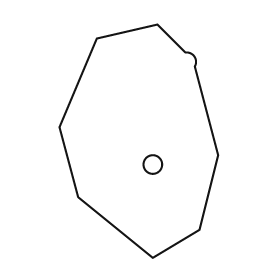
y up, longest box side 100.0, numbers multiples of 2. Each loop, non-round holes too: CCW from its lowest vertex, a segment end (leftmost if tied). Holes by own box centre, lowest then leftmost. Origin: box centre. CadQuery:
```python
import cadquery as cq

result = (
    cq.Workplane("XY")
    .moveTo(6.0, -50.0)
    .lineTo(26.0, -38.0)
    .lineTo(34.0, -6.0)
    .lineTo(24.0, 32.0)
    .threePointArc((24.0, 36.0), (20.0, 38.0))
    .lineTo(8.0, 50.0)
    .lineTo(-18.0, 44.0)
    .lineTo(-34.0, 6.0)
    .lineTo(-26.0, -24.0)
    .close()
    .moveTo(6.0, -10.0)
    .circle(4.0)
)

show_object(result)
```